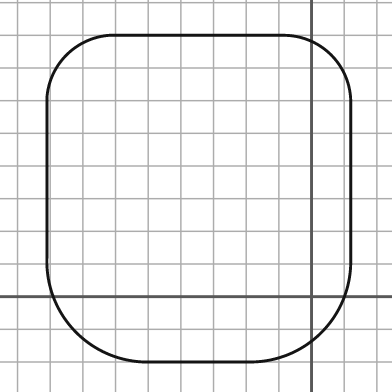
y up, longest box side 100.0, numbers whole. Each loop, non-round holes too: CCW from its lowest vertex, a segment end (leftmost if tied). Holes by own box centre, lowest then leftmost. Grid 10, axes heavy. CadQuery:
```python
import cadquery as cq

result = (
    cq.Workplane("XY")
    .moveTo(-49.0, -20.0)
    .lineTo(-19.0, -20.0)
    .threePointArc((3.0, -11.0), (12.0, 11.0))
    .lineTo(12.0, 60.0)
    .threePointArc((6.0, 74.0), (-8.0, 80.0))
    .lineTo(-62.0, 80.0)
    .threePointArc((-75.0, 74.0), (-81.0, 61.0))
    .lineTo(-81.0, 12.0)
    .threePointArc((-72.0, -11.0), (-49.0, -20.0))
    .close()
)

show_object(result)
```